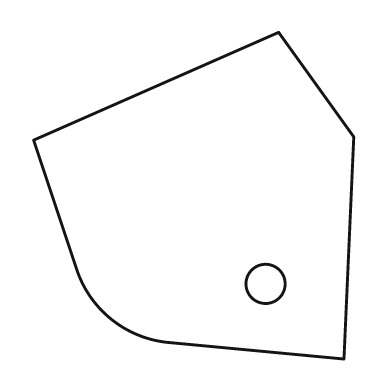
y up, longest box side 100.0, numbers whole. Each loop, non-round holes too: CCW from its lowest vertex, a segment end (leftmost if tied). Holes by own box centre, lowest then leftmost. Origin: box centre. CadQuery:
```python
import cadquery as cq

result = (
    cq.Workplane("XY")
    .moveTo(46.0, -50.0)
    .lineTo(49.0, 18.0)
    .lineTo(26.0, 50.0)
    .lineTo(-49.0, 17.0)
    .lineTo(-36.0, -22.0)
    .threePointArc((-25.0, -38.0), (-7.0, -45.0))
    .close()
    .moveTo(22.0, -27.0)
    .circle(6.0)
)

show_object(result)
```